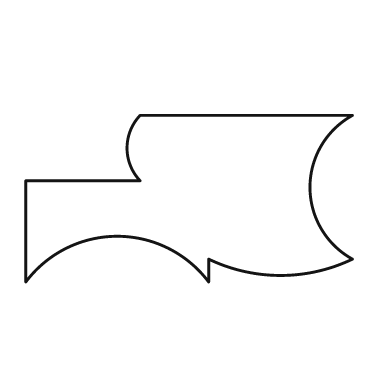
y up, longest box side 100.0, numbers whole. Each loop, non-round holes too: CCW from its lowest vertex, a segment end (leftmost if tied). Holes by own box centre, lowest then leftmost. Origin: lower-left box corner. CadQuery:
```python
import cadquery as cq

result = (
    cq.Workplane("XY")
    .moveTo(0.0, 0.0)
    .threePointArc((28.0, 14.0), (56.0, 0.0))
    .lineTo(56.0, 7.0)
    .threePointArc((78.0, 2.0), (100.0, 7.0))
    .threePointArc((87.0, 29.0), (100.0, 51.0))
    .lineTo(35.0, 51.0)
    .threePointArc((31.0, 41.0), (35.0, 31.0))
    .lineTo(0.0, 31.0)
    .close()
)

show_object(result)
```